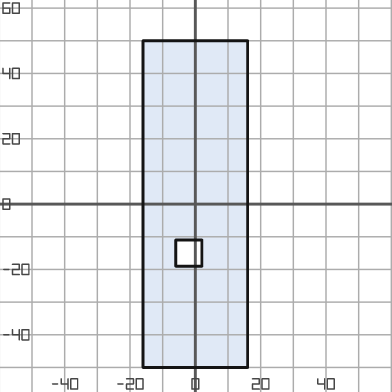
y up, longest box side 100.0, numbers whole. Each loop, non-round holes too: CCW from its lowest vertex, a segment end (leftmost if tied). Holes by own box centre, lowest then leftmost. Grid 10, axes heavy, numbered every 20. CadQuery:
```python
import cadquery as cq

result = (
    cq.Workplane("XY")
    .moveTo(-16.0, -50.0)
    .lineTo(16.0, -50.0)
    .lineTo(16.0, 50.0)
    .lineTo(-16.0, 50.0)
    .close()
    .moveTo(-6.0, -19.0)
    .lineTo(2.0, -19.0)
    .lineTo(2.0, -11.0)
    .lineTo(-6.0, -11.0)
    .close()
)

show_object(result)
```